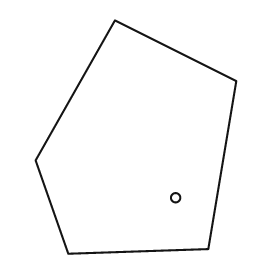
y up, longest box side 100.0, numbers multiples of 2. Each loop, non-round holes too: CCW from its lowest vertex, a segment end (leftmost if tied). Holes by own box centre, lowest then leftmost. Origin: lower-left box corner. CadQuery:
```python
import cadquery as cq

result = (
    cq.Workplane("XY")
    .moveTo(14.0, 0.0)
    .lineTo(74.0, 2.0)
    .lineTo(86.0, 74.0)
    .lineTo(34.0, 100.0)
    .lineTo(0.0, 40.0)
    .close()
    .moveTo(60.0, 24.0)
    .circle(2.0)
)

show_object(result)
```